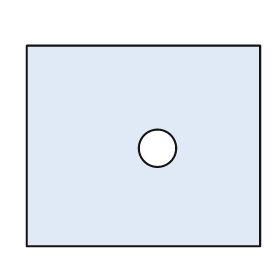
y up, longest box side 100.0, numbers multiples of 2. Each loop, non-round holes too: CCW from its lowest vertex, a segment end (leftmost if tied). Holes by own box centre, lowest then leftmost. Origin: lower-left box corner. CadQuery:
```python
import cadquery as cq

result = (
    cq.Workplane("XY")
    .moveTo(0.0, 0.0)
    .lineTo(100.0, 0.0)
    .lineTo(100.0, 86.0)
    .lineTo(0.0, 86.0)
    .close()
    .moveTo(56.0, 42.0)
    .circle(8.0)
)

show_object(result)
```